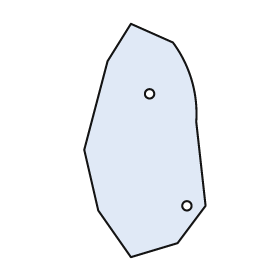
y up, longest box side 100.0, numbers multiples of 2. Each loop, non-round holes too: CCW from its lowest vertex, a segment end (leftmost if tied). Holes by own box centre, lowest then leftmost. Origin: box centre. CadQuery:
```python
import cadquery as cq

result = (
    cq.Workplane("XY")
    .moveTo(-6.0, -50.0)
    .lineTo(14.0, -44.0)
    .lineTo(26.0, -28.0)
    .lineTo(22.0, 8.0)
    .threePointArc((20.0, 26.0), (12.0, 42.0))
    .lineTo(-6.0, 50.0)
    .lineTo(-16.0, 34.0)
    .lineTo(-26.0, -4.0)
    .lineTo(-20.0, -30.0)
    .close()
    .moveTo(18.0, -28.0)
    .circle(2.0)
    .moveTo(2.0, 20.0)
    .circle(2.0)
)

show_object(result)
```